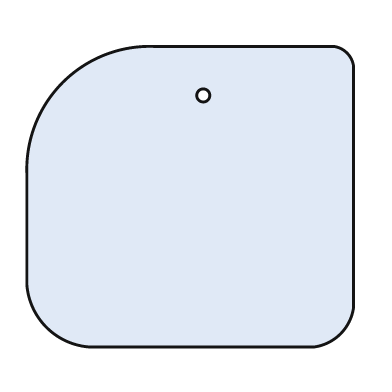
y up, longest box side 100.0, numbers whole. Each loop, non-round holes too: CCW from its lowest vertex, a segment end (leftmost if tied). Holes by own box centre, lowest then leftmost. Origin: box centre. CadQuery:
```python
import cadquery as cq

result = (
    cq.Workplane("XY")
    .moveTo(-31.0, -46.0)
    .lineTo(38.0, -46.0)
    .threePointArc((46.0, -42.0), (50.0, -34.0))
    .lineTo(50.0, 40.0)
    .threePointArc((48.0, 44.0), (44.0, 46.0))
    .lineTo(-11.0, 46.0)
    .threePointArc((-39.0, 35.0), (-50.0, 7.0))
    .lineTo(-50.0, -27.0)
    .threePointArc((-44.0, -40.0), (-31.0, -46.0))
    .close()
    .moveTo(4.0, 31.0)
    .circle(2.0)
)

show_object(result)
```